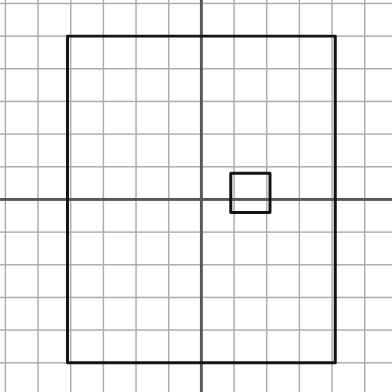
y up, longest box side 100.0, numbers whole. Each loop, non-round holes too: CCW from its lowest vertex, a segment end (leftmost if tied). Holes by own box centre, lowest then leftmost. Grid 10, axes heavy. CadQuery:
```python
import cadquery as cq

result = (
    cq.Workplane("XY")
    .moveTo(-41.0, -50.0)
    .lineTo(41.0, -50.0)
    .lineTo(41.0, 50.0)
    .lineTo(-41.0, 50.0)
    .close()
    .moveTo(9.0, -4.0)
    .lineTo(21.0, -4.0)
    .lineTo(21.0, 8.0)
    .lineTo(9.0, 8.0)
    .close()
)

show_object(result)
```